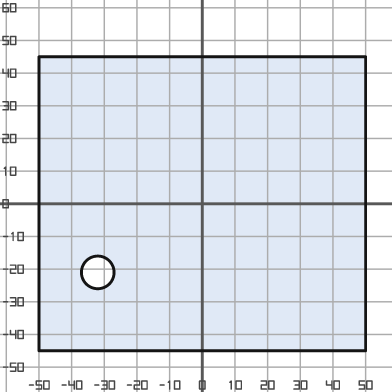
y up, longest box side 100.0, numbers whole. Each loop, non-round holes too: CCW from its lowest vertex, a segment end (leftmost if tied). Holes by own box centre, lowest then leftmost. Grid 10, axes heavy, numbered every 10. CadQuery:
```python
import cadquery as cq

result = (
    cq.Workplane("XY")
    .moveTo(-50.0, -45.0)
    .lineTo(50.0, -45.0)
    .lineTo(50.0, 45.0)
    .lineTo(-50.0, 45.0)
    .close()
    .moveTo(-32.0, -21.0)
    .circle(5.0)
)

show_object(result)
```